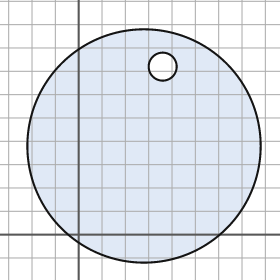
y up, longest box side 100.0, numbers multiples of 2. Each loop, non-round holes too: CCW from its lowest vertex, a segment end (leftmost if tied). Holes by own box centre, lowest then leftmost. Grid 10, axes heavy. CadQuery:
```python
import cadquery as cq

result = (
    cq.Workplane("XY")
    .moveTo(28.0, 38.0)
    .circle(50.0)
    .moveTo(36.0, 72.0)
    .circle(6.0)
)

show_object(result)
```